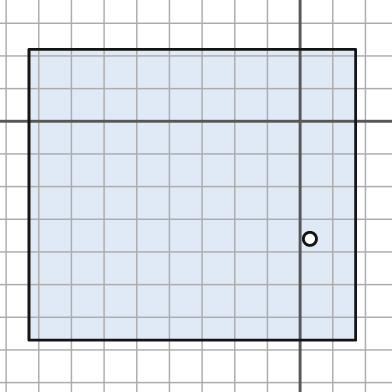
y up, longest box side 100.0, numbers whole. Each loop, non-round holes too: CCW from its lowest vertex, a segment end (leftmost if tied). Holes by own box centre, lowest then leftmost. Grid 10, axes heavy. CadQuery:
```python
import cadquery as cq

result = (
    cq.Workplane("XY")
    .moveTo(-83.0, -67.0)
    .lineTo(17.0, -67.0)
    .lineTo(17.0, 22.0)
    .lineTo(-83.0, 22.0)
    .close()
    .moveTo(3.0, -36.0)
    .circle(2.0)
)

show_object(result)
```